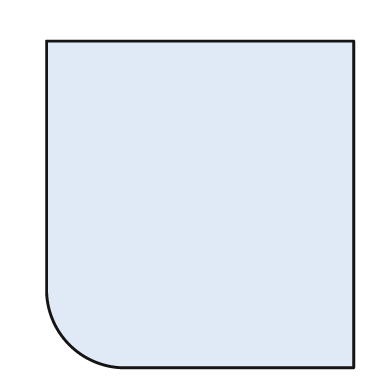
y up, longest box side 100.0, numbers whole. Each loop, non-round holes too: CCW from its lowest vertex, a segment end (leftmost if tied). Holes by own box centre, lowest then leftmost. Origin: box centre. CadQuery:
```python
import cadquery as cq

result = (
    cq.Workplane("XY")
    .moveTo(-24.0, -50.0)
    .lineTo(47.0, -50.0)
    .lineTo(47.0, 50.0)
    .lineTo(-47.0, 50.0)
    .lineTo(-47.0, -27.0)
    .threePointArc((-40.0, -43.0), (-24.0, -50.0))
    .close()
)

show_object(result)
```